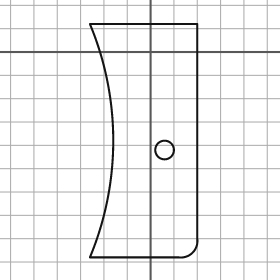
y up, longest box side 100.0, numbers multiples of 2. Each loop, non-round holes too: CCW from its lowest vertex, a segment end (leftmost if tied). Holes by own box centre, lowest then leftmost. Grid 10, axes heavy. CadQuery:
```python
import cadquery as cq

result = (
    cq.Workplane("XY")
    .moveTo(-26.0, -88.0)
    .lineTo(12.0, -88.0)
    .threePointArc((18.0, -86.0), (20.0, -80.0))
    .lineTo(20.0, 12.0)
    .lineTo(-26.0, 12.0)
    .threePointArc((-16.0, -38.0), (-26.0, -88.0))
    .close()
    .moveTo(6.0, -42.0)
    .circle(4.0)
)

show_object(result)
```